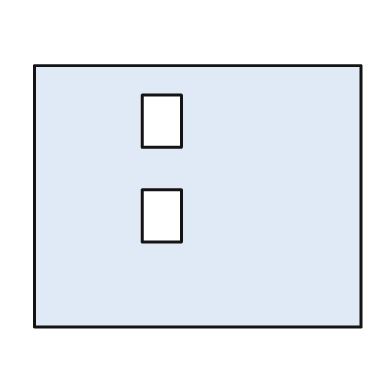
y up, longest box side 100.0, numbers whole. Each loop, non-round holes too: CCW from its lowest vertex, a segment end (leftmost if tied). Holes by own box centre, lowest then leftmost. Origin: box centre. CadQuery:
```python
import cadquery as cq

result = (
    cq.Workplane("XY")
    .moveTo(-50.0, -40.0)
    .lineTo(50.0, -40.0)
    .lineTo(50.0, 40.0)
    .lineTo(-50.0, 40.0)
    .close()
    .moveTo(-17.0, -14.0)
    .lineTo(-5.0, -14.0)
    .lineTo(-5.0, 2.0)
    .lineTo(-17.0, 2.0)
    .close()
    .moveTo(-17.0, 15.0)
    .lineTo(-5.0, 15.0)
    .lineTo(-5.0, 31.0)
    .lineTo(-17.0, 31.0)
    .close()
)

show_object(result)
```